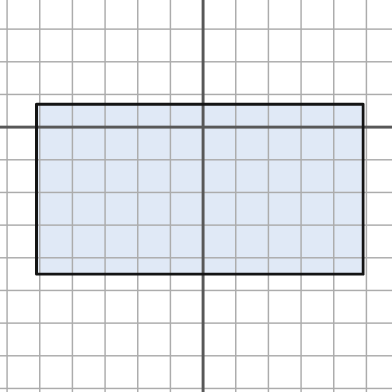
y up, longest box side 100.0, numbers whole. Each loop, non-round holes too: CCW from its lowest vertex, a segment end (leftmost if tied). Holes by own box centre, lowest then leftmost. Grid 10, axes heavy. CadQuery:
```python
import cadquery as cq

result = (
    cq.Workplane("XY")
    .moveTo(-51.0, -45.0)
    .lineTo(49.0, -45.0)
    .lineTo(49.0, 7.0)
    .lineTo(-51.0, 7.0)
    .close()
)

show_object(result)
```